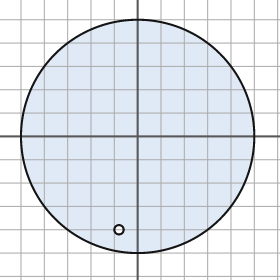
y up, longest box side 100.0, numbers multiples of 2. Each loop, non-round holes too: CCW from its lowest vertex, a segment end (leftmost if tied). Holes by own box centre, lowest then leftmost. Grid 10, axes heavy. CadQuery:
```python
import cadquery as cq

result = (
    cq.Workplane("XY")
    .moveTo(0.0, 0.0)
    .circle(50.0)
    .moveTo(-8.0, -40.0)
    .circle(2.0)
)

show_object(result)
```